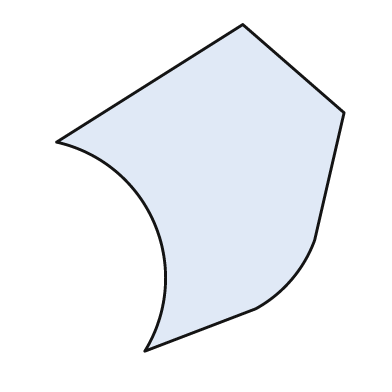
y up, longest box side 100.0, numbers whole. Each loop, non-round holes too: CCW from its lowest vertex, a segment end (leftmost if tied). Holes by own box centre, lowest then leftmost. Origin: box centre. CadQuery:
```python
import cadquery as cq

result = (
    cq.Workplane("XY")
    .moveTo(-17.0, -50.0)
    .lineTo(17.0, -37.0)
    .threePointArc((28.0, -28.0), (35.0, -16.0))
    .lineTo(44.0, 23.0)
    .lineTo(13.0, 50.0)
    .lineTo(-44.0, 14.0)
    .threePointArc((-14.0, -11.0), (-17.0, -50.0))
    .close()
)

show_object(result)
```